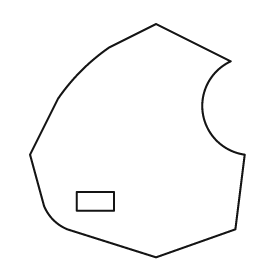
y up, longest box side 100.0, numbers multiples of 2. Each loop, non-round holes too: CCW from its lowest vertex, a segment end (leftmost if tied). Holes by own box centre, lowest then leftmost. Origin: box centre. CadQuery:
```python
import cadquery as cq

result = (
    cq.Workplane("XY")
    .moveTo(8.0, -50.0)
    .lineTo(42.0, -38.0)
    .lineTo(46.0, -6.0)
    .threePointArc((28.0, 12.0), (40.0, 34.0))
    .lineTo(8.0, 50.0)
    .lineTo(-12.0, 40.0)
    .threePointArc((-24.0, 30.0), (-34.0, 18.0))
    .lineTo(-46.0, -6.0)
    .lineTo(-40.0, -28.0)
    .threePointArc((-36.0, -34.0), (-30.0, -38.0))
    .close()
    .moveTo(-26.0, -30.0)
    .lineTo(-10.0, -30.0)
    .lineTo(-10.0, -22.0)
    .lineTo(-26.0, -22.0)
    .close()
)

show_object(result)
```